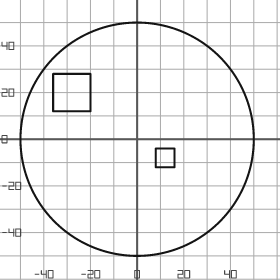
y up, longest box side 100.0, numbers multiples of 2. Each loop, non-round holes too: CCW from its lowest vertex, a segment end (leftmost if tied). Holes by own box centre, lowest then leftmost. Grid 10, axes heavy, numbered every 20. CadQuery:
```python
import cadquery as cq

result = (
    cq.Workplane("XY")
    .moveTo(0.0, 0.0)
    .circle(50.0)
    .moveTo(8.0, -12.0)
    .lineTo(16.0, -12.0)
    .lineTo(16.0, -4.0)
    .lineTo(8.0, -4.0)
    .close()
    .moveTo(-36.0, 12.0)
    .lineTo(-20.0, 12.0)
    .lineTo(-20.0, 28.0)
    .lineTo(-36.0, 28.0)
    .close()
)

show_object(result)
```